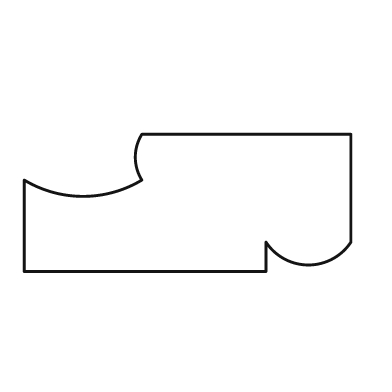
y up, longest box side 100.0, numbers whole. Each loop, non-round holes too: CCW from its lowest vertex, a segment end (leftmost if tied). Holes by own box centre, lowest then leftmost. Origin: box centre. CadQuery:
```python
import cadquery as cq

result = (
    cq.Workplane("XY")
    .moveTo(-50.0, -21.0)
    .lineTo(24.0, -21.0)
    .lineTo(24.0, -12.0)
    .threePointArc((37.0, -19.0), (50.0, -12.0))
    .lineTo(50.0, 21.0)
    .lineTo(-14.0, 21.0)
    .threePointArc((-16.0, 14.0), (-14.0, 7.0))
    .threePointArc((-32.0, 2.0), (-50.0, 7.0))
    .close()
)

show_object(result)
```